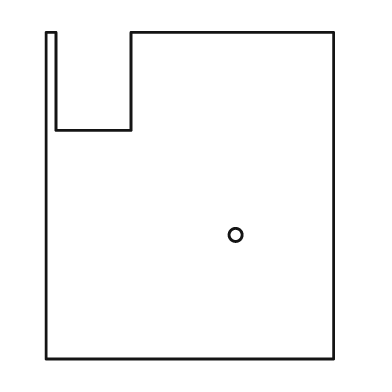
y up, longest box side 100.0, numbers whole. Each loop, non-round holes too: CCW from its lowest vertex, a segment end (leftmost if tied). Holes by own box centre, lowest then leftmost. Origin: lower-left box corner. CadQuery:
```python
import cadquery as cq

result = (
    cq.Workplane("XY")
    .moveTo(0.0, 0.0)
    .lineTo(88.0, 0.0)
    .lineTo(88.0, 100.0)
    .lineTo(26.0, 100.0)
    .lineTo(26.0, 70.0)
    .lineTo(3.0, 70.0)
    .lineTo(3.0, 100.0)
    .lineTo(0.0, 100.0)
    .close()
    .moveTo(58.0, 38.0)
    .circle(2.0)
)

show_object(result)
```